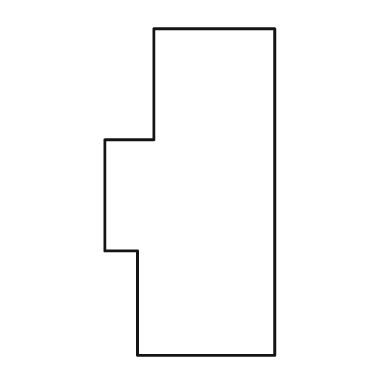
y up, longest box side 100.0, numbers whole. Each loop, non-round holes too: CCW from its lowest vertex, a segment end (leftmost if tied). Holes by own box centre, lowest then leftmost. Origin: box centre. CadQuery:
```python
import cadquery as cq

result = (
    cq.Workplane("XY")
    .moveTo(-16.0, -50.0)
    .lineTo(26.0, -50.0)
    .lineTo(26.0, 50.0)
    .lineTo(-11.0, 50.0)
    .lineTo(-11.0, 16.0)
    .lineTo(-26.0, 16.0)
    .lineTo(-26.0, -18.0)
    .lineTo(-16.0, -18.0)
    .close()
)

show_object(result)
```